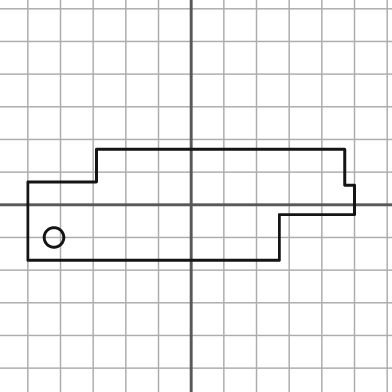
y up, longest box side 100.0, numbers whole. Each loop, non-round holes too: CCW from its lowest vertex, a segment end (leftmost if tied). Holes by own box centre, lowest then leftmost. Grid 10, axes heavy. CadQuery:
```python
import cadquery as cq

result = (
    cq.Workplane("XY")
    .moveTo(-50.0, -17.0)
    .lineTo(27.0, -17.0)
    .lineTo(27.0, -3.0)
    .lineTo(50.0, -3.0)
    .lineTo(50.0, 6.0)
    .lineTo(47.0, 6.0)
    .lineTo(47.0, 17.0)
    .lineTo(-29.0, 17.0)
    .lineTo(-29.0, 7.0)
    .lineTo(-50.0, 7.0)
    .close()
    .moveTo(-42.0, -10.0)
    .circle(3.0)
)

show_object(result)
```